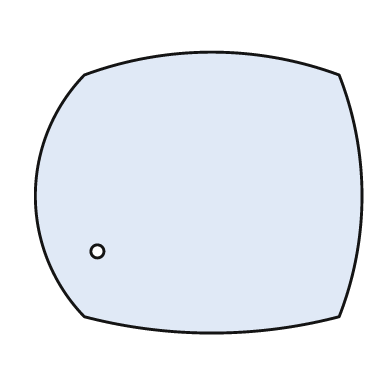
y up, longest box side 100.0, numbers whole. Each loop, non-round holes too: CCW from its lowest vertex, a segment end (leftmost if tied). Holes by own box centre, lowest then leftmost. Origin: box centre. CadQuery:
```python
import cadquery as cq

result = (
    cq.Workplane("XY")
    .moveTo(-35.0, -38.0)
    .threePointArc((4.0, -43.0), (43.0, -38.0))
    .threePointArc((50.0, -1.0), (43.0, 36.0))
    .threePointArc((4.0, 43.0), (-35.0, 36.0))
    .threePointArc((-50.0, -1.0), (-35.0, -38.0))
    .close()
    .moveTo(-31.0, -18.0)
    .circle(2.0)
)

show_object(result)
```